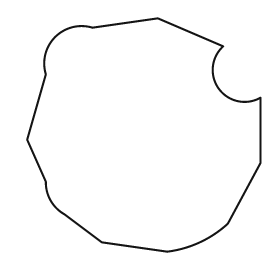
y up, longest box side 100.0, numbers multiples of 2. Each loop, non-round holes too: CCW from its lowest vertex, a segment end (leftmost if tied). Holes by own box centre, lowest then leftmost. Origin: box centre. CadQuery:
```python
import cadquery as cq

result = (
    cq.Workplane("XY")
    .moveTo(10.0, -50.0)
    .threePointArc((24.0, -46.0), (36.0, -38.0))
    .lineTo(50.0, -12.0)
    .lineTo(50.0, 16.0)
    .threePointArc((32.0, 20.0), (34.0, 38.0))
    .lineTo(6.0, 50.0)
    .lineTo(-22.0, 46.0)
    .threePointArc((-38.0, 42.0), (-42.0, 26.0))
    .lineTo(-50.0, -2.0)
    .lineTo(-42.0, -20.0)
    .threePointArc((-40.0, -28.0), (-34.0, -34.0))
    .lineTo(-18.0, -46.0)
    .close()
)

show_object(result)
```